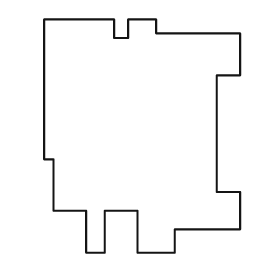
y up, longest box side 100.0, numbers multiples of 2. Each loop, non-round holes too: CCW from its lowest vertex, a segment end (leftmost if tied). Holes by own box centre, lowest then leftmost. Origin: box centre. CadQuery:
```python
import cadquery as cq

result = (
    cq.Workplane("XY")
    .moveTo(-24.0, -50.0)
    .lineTo(-16.0, -50.0)
    .lineTo(-16.0, -32.0)
    .lineTo(-2.0, -32.0)
    .lineTo(-2.0, -50.0)
    .lineTo(14.0, -50.0)
    .lineTo(14.0, -40.0)
    .lineTo(42.0, -40.0)
    .lineTo(42.0, -24.0)
    .lineTo(32.0, -24.0)
    .lineTo(32.0, 26.0)
    .lineTo(42.0, 26.0)
    .lineTo(42.0, 44.0)
    .lineTo(6.0, 44.0)
    .lineTo(6.0, 50.0)
    .lineTo(-6.0, 50.0)
    .lineTo(-6.0, 42.0)
    .lineTo(-12.0, 42.0)
    .lineTo(-12.0, 50.0)
    .lineTo(-42.0, 50.0)
    .lineTo(-42.0, -10.0)
    .lineTo(-38.0, -10.0)
    .lineTo(-38.0, -32.0)
    .lineTo(-24.0, -32.0)
    .close()
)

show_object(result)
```